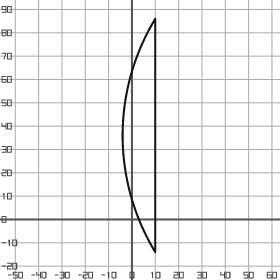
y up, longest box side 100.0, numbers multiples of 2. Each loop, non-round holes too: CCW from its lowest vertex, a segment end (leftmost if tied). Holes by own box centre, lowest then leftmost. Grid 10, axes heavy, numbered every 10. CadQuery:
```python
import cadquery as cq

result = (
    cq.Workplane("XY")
    .moveTo(10.0, -14.0)
    .lineTo(10.0, 86.0)
    .threePointArc((-4.0, 36.0), (10.0, -14.0))
    .close()
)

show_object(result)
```